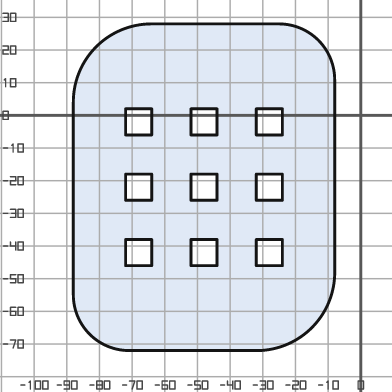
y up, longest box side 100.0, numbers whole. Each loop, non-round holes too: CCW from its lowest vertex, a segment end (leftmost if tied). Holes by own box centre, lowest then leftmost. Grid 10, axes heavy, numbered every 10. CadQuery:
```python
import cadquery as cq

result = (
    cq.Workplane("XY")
    .moveTo(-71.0, -72.0)
    .lineTo(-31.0, -72.0)
    .threePointArc((-15.0, -65.0), (-8.0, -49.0))
    .lineTo(-8.0, 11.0)
    .threePointArc((-13.0, 23.0), (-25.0, 28.0))
    .lineTo(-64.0, 28.0)
    .threePointArc((-81.0, 21.0), (-88.0, 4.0))
    .lineTo(-88.0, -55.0)
    .threePointArc((-83.0, -67.0), (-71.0, -72.0))
    .close()
    .moveTo(-72.0, -46.0)
    .lineTo(-64.0, -46.0)
    .lineTo(-64.0, -38.0)
    .lineTo(-72.0, -38.0)
    .close()
    .moveTo(-52.0, -46.0)
    .lineTo(-44.0, -46.0)
    .lineTo(-44.0, -38.0)
    .lineTo(-52.0, -38.0)
    .close()
    .moveTo(-32.0, -46.0)
    .lineTo(-24.0, -46.0)
    .lineTo(-24.0, -38.0)
    .lineTo(-32.0, -38.0)
    .close()
    .moveTo(-72.0, -26.0)
    .lineTo(-64.0, -26.0)
    .lineTo(-64.0, -18.0)
    .lineTo(-72.0, -18.0)
    .close()
    .moveTo(-52.0, -26.0)
    .lineTo(-44.0, -26.0)
    .lineTo(-44.0, -18.0)
    .lineTo(-52.0, -18.0)
    .close()
    .moveTo(-32.0, -26.0)
    .lineTo(-24.0, -26.0)
    .lineTo(-24.0, -18.0)
    .lineTo(-32.0, -18.0)
    .close()
    .moveTo(-72.0, -6.0)
    .lineTo(-64.0, -6.0)
    .lineTo(-64.0, 2.0)
    .lineTo(-72.0, 2.0)
    .close()
    .moveTo(-52.0, -6.0)
    .lineTo(-44.0, -6.0)
    .lineTo(-44.0, 2.0)
    .lineTo(-52.0, 2.0)
    .close()
    .moveTo(-32.0, -6.0)
    .lineTo(-24.0, -6.0)
    .lineTo(-24.0, 2.0)
    .lineTo(-32.0, 2.0)
    .close()
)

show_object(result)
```